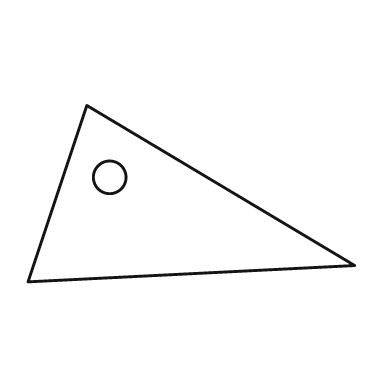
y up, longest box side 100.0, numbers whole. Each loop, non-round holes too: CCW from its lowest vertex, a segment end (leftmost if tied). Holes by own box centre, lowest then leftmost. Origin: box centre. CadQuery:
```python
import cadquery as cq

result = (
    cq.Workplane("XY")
    .moveTo(-50.0, -27.0)
    .lineTo(50.0, -22.0)
    .lineTo(-32.0, 27.0)
    .close()
    .moveTo(-25.0, 5.0)
    .circle(5.0)
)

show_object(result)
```